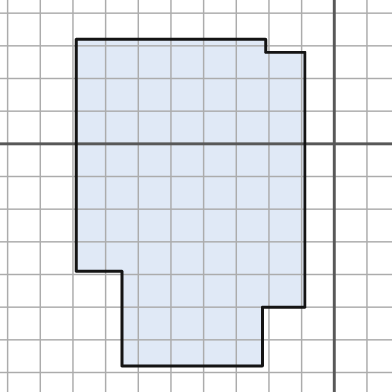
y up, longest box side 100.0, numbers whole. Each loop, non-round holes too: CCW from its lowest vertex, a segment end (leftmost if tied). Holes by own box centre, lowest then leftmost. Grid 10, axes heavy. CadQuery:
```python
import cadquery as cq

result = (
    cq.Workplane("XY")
    .moveTo(-65.0, -68.0)
    .lineTo(-22.0, -68.0)
    .lineTo(-22.0, -50.0)
    .lineTo(-9.0, -50.0)
    .lineTo(-9.0, 28.0)
    .lineTo(-21.0, 28.0)
    .lineTo(-21.0, 32.0)
    .lineTo(-79.0, 32.0)
    .lineTo(-79.0, -39.0)
    .lineTo(-65.0, -39.0)
    .close()
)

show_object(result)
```